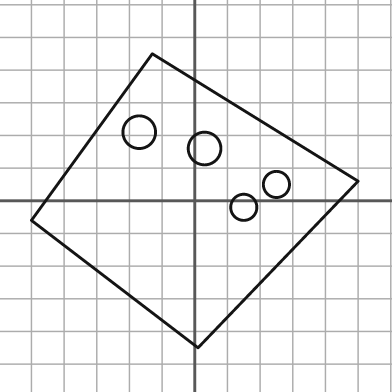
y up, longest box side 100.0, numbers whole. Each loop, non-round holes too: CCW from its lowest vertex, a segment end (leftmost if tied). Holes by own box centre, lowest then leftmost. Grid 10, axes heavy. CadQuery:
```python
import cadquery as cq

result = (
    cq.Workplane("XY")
    .moveTo(1.0, -45.0)
    .lineTo(50.0, 6.0)
    .lineTo(-13.0, 45.0)
    .lineTo(-50.0, -6.0)
    .close()
    .moveTo(15.0, -2.0)
    .circle(4.0)
    .moveTo(25.0, 5.0)
    .circle(4.0)
    .moveTo(3.0, 16.0)
    .circle(5.0)
    .moveTo(-17.0, 21.0)
    .circle(5.0)
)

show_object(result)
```